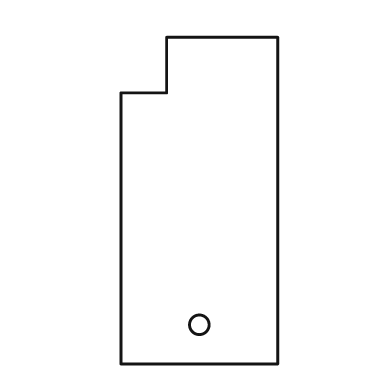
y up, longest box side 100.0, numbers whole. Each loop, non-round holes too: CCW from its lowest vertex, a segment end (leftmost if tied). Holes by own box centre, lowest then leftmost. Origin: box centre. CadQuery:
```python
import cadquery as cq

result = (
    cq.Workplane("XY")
    .moveTo(-24.0, -50.0)
    .lineTo(24.0, -50.0)
    .lineTo(24.0, 50.0)
    .lineTo(-10.0, 50.0)
    .lineTo(-10.0, 33.0)
    .lineTo(-24.0, 33.0)
    .close()
    .moveTo(0.0, -38.0)
    .circle(3.0)
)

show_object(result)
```